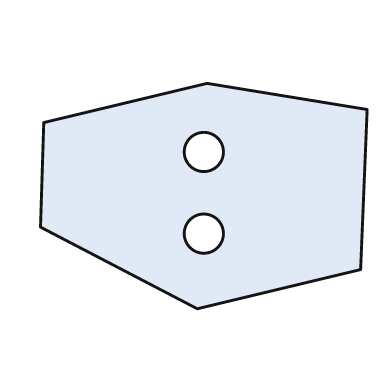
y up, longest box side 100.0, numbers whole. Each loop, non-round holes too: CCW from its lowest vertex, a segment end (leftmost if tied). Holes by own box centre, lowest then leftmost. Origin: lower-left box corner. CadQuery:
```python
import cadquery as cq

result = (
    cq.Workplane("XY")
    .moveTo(48.0, 0.0)
    .lineTo(98.0, 12.0)
    .lineTo(100.0, 61.0)
    .lineTo(51.0, 69.0)
    .lineTo(1.0, 57.0)
    .lineTo(0.0, 25.0)
    .close()
    .moveTo(50.0, 23.0)
    .circle(6.0)
    .moveTo(50.0, 48.0)
    .circle(6.0)
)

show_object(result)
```